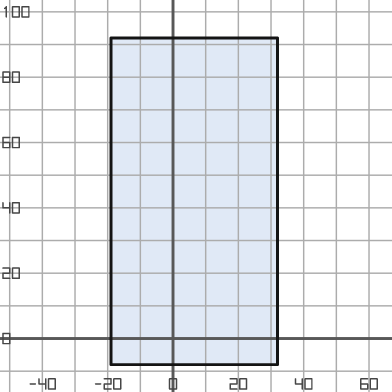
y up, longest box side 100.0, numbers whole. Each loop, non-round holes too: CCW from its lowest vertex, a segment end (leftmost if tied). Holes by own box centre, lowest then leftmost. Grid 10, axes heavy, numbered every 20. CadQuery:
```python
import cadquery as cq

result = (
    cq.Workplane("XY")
    .moveTo(-19.0, -8.0)
    .lineTo(32.0, -8.0)
    .lineTo(32.0, 92.0)
    .lineTo(-19.0, 92.0)
    .close()
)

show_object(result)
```